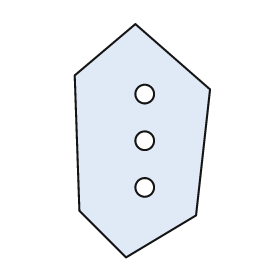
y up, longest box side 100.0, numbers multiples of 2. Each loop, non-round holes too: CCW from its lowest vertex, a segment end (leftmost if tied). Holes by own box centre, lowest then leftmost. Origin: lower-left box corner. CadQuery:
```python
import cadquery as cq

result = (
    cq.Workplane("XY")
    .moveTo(22.0, 0.0)
    .lineTo(52.0, 18.0)
    .lineTo(58.0, 72.0)
    .lineTo(26.0, 100.0)
    .lineTo(0.0, 78.0)
    .lineTo(2.0, 20.0)
    .close()
    .moveTo(30.0, 30.0)
    .circle(4.0)
    .moveTo(30.0, 50.0)
    .circle(4.0)
    .moveTo(30.0, 70.0)
    .circle(4.0)
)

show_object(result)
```